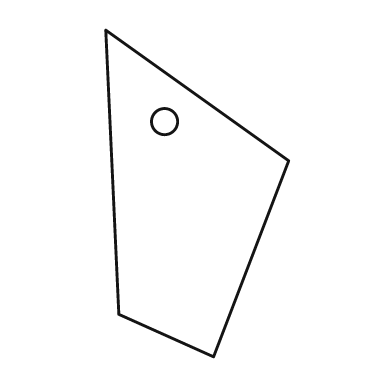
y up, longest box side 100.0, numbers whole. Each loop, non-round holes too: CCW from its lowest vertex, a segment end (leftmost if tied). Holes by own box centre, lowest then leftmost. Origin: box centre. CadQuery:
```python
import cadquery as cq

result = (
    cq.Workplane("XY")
    .moveTo(5.0, -50.0)
    .lineTo(28.0, 10.0)
    .lineTo(-28.0, 50.0)
    .lineTo(-24.0, -37.0)
    .close()
    .moveTo(-10.0, 22.0)
    .circle(4.0)
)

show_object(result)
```